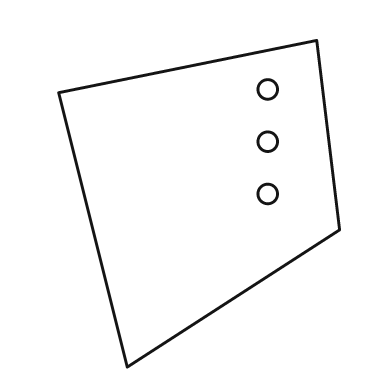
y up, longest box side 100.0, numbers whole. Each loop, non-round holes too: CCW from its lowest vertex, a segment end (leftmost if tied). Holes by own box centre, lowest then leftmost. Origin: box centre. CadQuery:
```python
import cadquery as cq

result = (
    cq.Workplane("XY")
    .moveTo(-22.0, -50.0)
    .lineTo(43.0, -8.0)
    .lineTo(36.0, 50.0)
    .lineTo(-43.0, 34.0)
    .close()
    .moveTo(21.0, 3.0)
    .circle(3.0)
    .moveTo(21.0, 19.0)
    .circle(3.0)
    .moveTo(21.0, 35.0)
    .circle(3.0)
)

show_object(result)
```